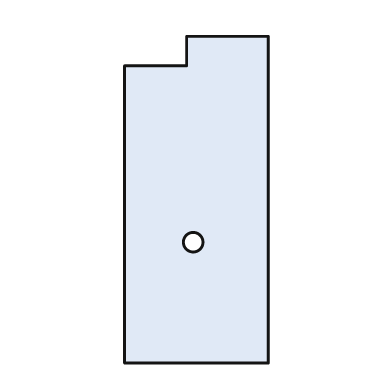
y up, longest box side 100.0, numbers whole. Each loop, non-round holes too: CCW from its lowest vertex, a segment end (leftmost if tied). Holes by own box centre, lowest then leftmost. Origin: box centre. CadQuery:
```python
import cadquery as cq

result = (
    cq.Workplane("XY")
    .moveTo(-22.0, -50.0)
    .lineTo(22.0, -50.0)
    .lineTo(22.0, 50.0)
    .lineTo(-3.0, 50.0)
    .lineTo(-3.0, 41.0)
    .lineTo(-22.0, 41.0)
    .close()
    .moveTo(-1.0, -13.0)
    .circle(3.0)
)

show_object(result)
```